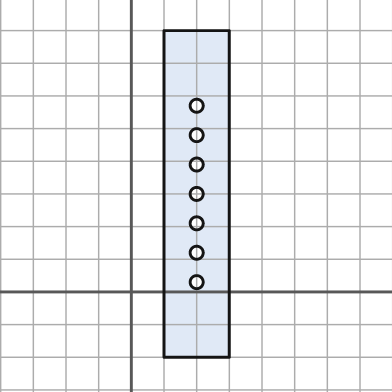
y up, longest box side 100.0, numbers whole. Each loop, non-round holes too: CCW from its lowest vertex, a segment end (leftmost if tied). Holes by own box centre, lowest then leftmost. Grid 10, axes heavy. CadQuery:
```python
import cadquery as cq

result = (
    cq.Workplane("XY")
    .moveTo(10.0, -20.0)
    .lineTo(30.0, -20.0)
    .lineTo(30.0, 80.0)
    .lineTo(10.0, 80.0)
    .close()
    .moveTo(20.0, 3.0)
    .circle(2.0)
    .moveTo(20.0, 12.0)
    .circle(2.0)
    .moveTo(20.0, 21.0)
    .circle(2.0)
    .moveTo(20.0, 30.0)
    .circle(2.0)
    .moveTo(20.0, 39.0)
    .circle(2.0)
    .moveTo(20.0, 48.0)
    .circle(2.0)
    .moveTo(20.0, 57.0)
    .circle(2.0)
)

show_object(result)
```